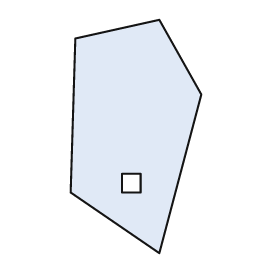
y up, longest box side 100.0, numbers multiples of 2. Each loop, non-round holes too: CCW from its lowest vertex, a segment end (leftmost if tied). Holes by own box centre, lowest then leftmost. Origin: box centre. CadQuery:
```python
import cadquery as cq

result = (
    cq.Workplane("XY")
    .moveTo(10.0, -50.0)
    .lineTo(28.0, 18.0)
    .lineTo(10.0, 50.0)
    .lineTo(-26.0, 42.0)
    .lineTo(-28.0, -24.0)
    .close()
    .moveTo(-6.0, -24.0)
    .lineTo(2.0, -24.0)
    .lineTo(2.0, -16.0)
    .lineTo(-6.0, -16.0)
    .close()
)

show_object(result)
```